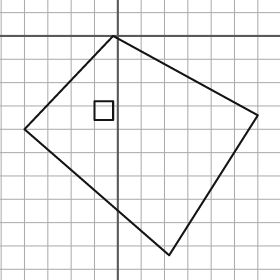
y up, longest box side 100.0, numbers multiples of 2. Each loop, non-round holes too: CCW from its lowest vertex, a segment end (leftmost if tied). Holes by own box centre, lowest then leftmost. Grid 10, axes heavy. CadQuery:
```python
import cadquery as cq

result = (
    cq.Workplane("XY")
    .moveTo(22.0, -94.0)
    .lineTo(60.0, -34.0)
    .lineTo(-2.0, 0.0)
    .lineTo(-40.0, -40.0)
    .close()
    .moveTo(-10.0, -36.0)
    .lineTo(-2.0, -36.0)
    .lineTo(-2.0, -28.0)
    .lineTo(-10.0, -28.0)
    .close()
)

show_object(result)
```